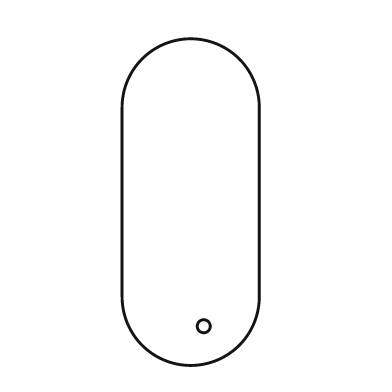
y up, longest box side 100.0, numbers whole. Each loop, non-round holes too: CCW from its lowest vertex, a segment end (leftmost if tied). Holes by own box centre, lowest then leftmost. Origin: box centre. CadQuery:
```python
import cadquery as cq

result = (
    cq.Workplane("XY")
    .moveTo(-21.0, -29.0)
    .threePointArc((0.0, -50.0), (21.0, -29.0))
    .lineTo(21.0, 29.0)
    .threePointArc((0.0, 50.0), (-21.0, 29.0))
    .close()
    .moveTo(4.0, -38.0)
    .circle(2.0)
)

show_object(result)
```